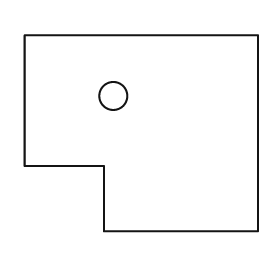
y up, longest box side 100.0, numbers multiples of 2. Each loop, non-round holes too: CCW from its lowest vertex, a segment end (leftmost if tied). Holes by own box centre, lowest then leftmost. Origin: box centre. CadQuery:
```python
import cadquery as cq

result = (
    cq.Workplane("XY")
    .moveTo(-16.0, -42.0)
    .lineTo(50.0, -42.0)
    .lineTo(50.0, 42.0)
    .lineTo(-50.0, 42.0)
    .lineTo(-50.0, -14.0)
    .lineTo(-16.0, -14.0)
    .close()
    .moveTo(-12.0, 16.0)
    .circle(6.0)
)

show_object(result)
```